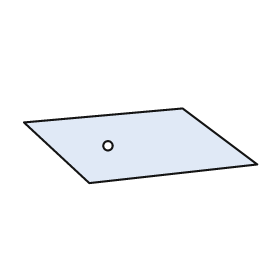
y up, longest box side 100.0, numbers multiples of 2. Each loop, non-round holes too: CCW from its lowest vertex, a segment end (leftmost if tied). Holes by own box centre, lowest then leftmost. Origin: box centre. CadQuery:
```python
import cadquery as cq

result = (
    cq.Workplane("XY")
    .moveTo(-22.0, -16.0)
    .lineTo(50.0, -8.0)
    .lineTo(18.0, 16.0)
    .lineTo(-50.0, 10.0)
    .close()
    .moveTo(-14.0, 0.0)
    .circle(2.0)
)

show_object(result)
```